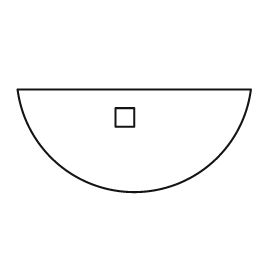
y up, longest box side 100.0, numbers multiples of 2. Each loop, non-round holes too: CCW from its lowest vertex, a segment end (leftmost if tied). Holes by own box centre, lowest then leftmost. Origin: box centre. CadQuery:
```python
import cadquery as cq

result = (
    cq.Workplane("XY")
    .moveTo(-50.0, 22.0)
    .threePointArc((0.0, -22.0), (50.0, 22.0))
    .close()
    .moveTo(-8.0, 6.0)
    .lineTo(0.0, 6.0)
    .lineTo(0.0, 14.0)
    .lineTo(-8.0, 14.0)
    .close()
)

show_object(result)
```